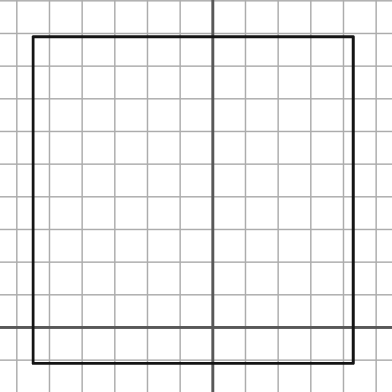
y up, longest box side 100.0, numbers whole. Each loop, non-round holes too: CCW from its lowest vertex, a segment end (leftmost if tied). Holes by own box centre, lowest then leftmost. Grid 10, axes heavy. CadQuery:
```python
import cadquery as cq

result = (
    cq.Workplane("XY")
    .moveTo(-55.0, -11.0)
    .lineTo(43.0, -11.0)
    .lineTo(43.0, 89.0)
    .lineTo(-55.0, 89.0)
    .close()
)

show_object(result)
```